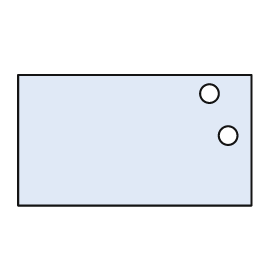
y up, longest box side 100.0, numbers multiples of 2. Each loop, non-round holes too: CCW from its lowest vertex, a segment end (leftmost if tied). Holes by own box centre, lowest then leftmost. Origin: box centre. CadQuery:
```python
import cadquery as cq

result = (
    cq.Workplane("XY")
    .moveTo(-50.0, -28.0)
    .lineTo(50.0, -28.0)
    .lineTo(50.0, 28.0)
    .lineTo(-50.0, 28.0)
    .close()
    .moveTo(40.0, 2.0)
    .circle(4.0)
    .moveTo(32.0, 20.0)
    .circle(4.0)
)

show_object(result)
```